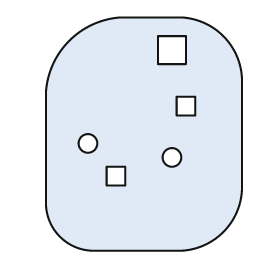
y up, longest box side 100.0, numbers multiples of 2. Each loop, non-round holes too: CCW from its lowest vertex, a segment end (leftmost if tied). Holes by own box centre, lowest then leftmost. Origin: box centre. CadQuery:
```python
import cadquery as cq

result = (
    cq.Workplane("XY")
    .moveTo(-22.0, -50.0)
    .lineTo(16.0, -50.0)
    .threePointArc((34.0, -42.0), (42.0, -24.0))
    .lineTo(42.0, 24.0)
    .threePointArc((34.0, 42.0), (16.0, 50.0))
    .lineTo(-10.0, 50.0)
    .threePointArc((-32.0, 40.0), (-42.0, 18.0))
    .lineTo(-42.0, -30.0)
    .threePointArc((-36.0, -44.0), (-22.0, -50.0))
    .close()
    .moveTo(-16.0, -22.0)
    .lineTo(-8.0, -22.0)
    .lineTo(-8.0, -14.0)
    .lineTo(-16.0, -14.0)
    .close()
    .moveTo(12.0, -10.0)
    .circle(4.0)
    .moveTo(-24.0, -4.0)
    .circle(4.0)
    .moveTo(14.0, 8.0)
    .lineTo(22.0, 8.0)
    .lineTo(22.0, 16.0)
    .lineTo(14.0, 16.0)
    .close()
    .moveTo(6.0, 30.0)
    .lineTo(18.0, 30.0)
    .lineTo(18.0, 42.0)
    .lineTo(6.0, 42.0)
    .close()
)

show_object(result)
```